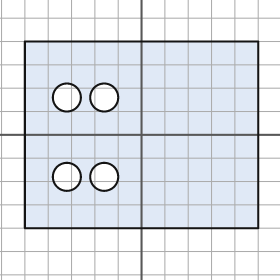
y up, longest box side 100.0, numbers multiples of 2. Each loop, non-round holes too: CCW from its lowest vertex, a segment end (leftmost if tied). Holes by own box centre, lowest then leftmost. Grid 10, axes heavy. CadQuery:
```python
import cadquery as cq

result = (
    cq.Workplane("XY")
    .moveTo(-50.0, -40.0)
    .lineTo(50.0, -40.0)
    .lineTo(50.0, 40.0)
    .lineTo(-50.0, 40.0)
    .close()
    .moveTo(-32.0, -18.0)
    .circle(6.0)
    .moveTo(-16.0, -18.0)
    .circle(6.0)
    .moveTo(-32.0, 16.0)
    .circle(6.0)
    .moveTo(-16.0, 16.0)
    .circle(6.0)
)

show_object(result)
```